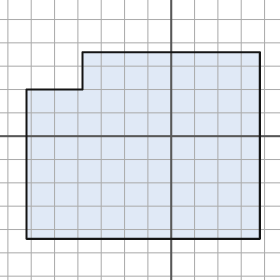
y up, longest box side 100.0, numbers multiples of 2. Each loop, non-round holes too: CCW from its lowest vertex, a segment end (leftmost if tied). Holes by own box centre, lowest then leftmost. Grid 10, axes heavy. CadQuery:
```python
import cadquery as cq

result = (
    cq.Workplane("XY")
    .moveTo(-62.0, -44.0)
    .lineTo(38.0, -44.0)
    .lineTo(38.0, 36.0)
    .lineTo(-38.0, 36.0)
    .lineTo(-38.0, 20.0)
    .lineTo(-62.0, 20.0)
    .close()
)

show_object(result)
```